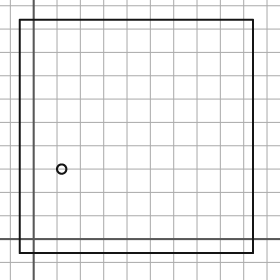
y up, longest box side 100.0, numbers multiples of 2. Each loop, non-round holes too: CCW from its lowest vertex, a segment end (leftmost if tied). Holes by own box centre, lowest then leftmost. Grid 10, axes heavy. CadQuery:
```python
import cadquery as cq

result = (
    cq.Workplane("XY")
    .moveTo(-6.0, -6.0)
    .lineTo(94.0, -6.0)
    .lineTo(94.0, 94.0)
    .lineTo(-6.0, 94.0)
    .close()
    .moveTo(12.0, 30.0)
    .circle(2.0)
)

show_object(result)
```